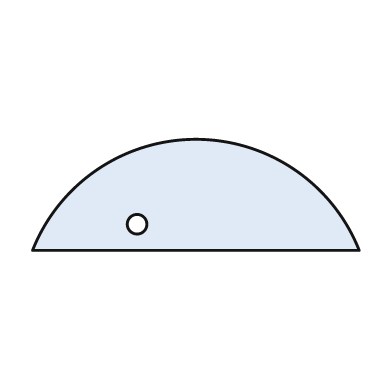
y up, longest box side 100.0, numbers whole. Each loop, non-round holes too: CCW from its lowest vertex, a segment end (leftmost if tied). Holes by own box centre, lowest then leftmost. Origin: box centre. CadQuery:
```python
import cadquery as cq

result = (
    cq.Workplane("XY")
    .moveTo(-50.0, -17.0)
    .lineTo(50.0, -17.0)
    .threePointArc((0.0, 17.0), (-50.0, -17.0))
    .close()
    .moveTo(-18.0, -9.0)
    .circle(3.0)
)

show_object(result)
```